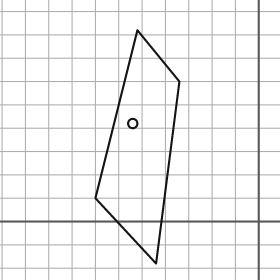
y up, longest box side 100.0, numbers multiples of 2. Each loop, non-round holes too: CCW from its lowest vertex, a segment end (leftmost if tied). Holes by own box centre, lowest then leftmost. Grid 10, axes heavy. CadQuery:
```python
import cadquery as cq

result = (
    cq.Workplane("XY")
    .moveTo(-44.0, -18.0)
    .lineTo(-34.0, 60.0)
    .lineTo(-52.0, 82.0)
    .lineTo(-70.0, 10.0)
    .close()
    .moveTo(-54.0, 42.0)
    .circle(2.0)
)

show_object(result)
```